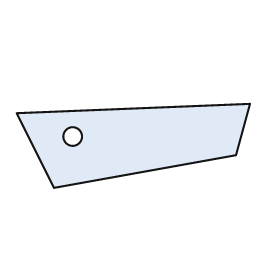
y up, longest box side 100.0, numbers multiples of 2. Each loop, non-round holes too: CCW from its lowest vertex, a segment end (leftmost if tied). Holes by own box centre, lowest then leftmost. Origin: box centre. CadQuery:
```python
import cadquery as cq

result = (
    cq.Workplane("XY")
    .moveTo(-34.0, -18.0)
    .lineTo(44.0, -4.0)
    .lineTo(50.0, 18.0)
    .lineTo(-50.0, 14.0)
    .close()
    .moveTo(-26.0, 4.0)
    .circle(4.0)
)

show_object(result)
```